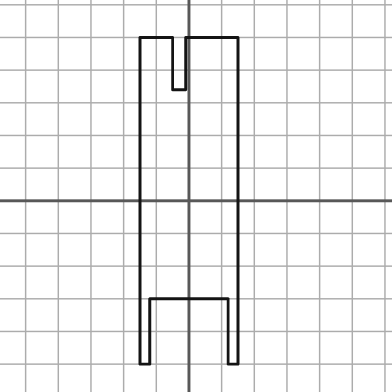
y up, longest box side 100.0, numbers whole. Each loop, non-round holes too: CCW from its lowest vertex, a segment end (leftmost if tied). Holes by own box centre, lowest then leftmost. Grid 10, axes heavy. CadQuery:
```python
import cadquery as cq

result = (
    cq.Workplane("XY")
    .moveTo(-15.0, -50.0)
    .lineTo(-12.0, -50.0)
    .lineTo(-12.0, -30.0)
    .lineTo(12.0, -30.0)
    .lineTo(12.0, -50.0)
    .lineTo(15.0, -50.0)
    .lineTo(15.0, 50.0)
    .lineTo(-1.0, 50.0)
    .lineTo(-1.0, 34.0)
    .lineTo(-5.0, 34.0)
    .lineTo(-5.0, 50.0)
    .lineTo(-15.0, 50.0)
    .close()
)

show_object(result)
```